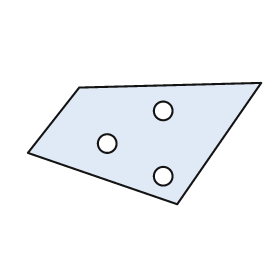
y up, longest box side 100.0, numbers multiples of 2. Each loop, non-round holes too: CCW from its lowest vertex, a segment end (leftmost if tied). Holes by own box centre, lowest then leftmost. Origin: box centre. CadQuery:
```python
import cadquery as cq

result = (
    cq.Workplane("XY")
    .moveTo(14.0, -26.0)
    .lineTo(50.0, 26.0)
    .lineTo(-28.0, 24.0)
    .lineTo(-50.0, -4.0)
    .close()
    .moveTo(8.0, -14.0)
    .circle(4.0)
    .moveTo(-16.0, 0.0)
    .circle(4.0)
    .moveTo(8.0, 14.0)
    .circle(4.0)
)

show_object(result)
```